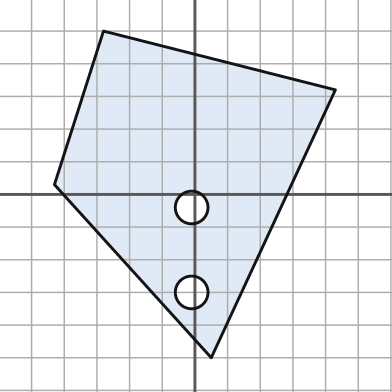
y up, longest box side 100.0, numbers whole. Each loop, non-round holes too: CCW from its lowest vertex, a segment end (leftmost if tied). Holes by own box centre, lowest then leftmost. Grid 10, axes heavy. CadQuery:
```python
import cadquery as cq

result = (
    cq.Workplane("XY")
    .moveTo(5.0, -50.0)
    .lineTo(43.0, 32.0)
    .lineTo(-28.0, 50.0)
    .lineTo(-43.0, 3.0)
    .close()
    .moveTo(-1.0, -30.0)
    .circle(5.0)
    .moveTo(-1.0, -4.0)
    .circle(5.0)
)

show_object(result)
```